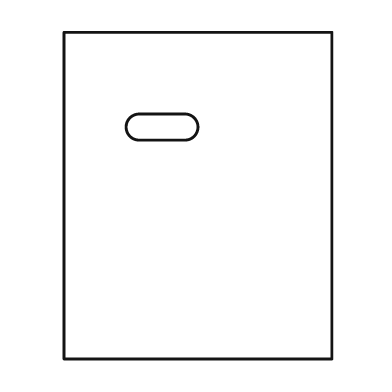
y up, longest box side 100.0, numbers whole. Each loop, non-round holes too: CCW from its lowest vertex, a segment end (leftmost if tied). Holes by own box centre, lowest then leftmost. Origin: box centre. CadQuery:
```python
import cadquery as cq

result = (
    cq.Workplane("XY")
    .moveTo(-41.0, -50.0)
    .lineTo(41.0, -50.0)
    .lineTo(41.0, 50.0)
    .lineTo(-41.0, 50.0)
    .close()
    .moveTo(-18.0, 17.0)
    .lineTo(-4.0, 17.0)
    .threePointArc((0.0, 21.0), (-4.0, 25.0))
    .lineTo(-18.0, 25.0)
    .threePointArc((-22.0, 21.0), (-18.0, 17.0))
    .close()
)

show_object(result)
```